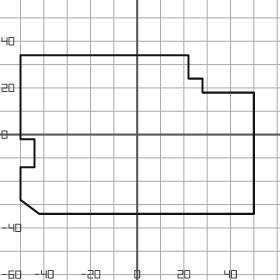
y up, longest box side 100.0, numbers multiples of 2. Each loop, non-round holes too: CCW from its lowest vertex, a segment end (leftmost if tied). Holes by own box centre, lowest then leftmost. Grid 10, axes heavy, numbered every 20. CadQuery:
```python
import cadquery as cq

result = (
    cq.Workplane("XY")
    .moveTo(-42.0, -34.0)
    .lineTo(50.0, -34.0)
    .lineTo(50.0, 18.0)
    .lineTo(28.0, 18.0)
    .lineTo(28.0, 24.0)
    .lineTo(22.0, 24.0)
    .lineTo(22.0, 34.0)
    .lineTo(-50.0, 34.0)
    .lineTo(-50.0, -2.0)
    .lineTo(-44.0, -2.0)
    .lineTo(-44.0, -14.0)
    .lineTo(-50.0, -14.0)
    .lineTo(-50.0, -28.0)
    .close()
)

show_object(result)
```